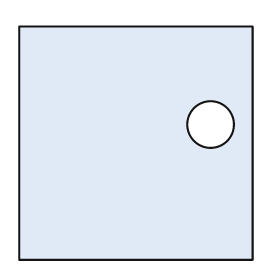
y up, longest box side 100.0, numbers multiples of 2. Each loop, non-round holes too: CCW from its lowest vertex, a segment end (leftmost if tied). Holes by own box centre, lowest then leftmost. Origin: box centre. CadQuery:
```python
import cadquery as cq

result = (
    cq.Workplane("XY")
    .moveTo(-50.0, -50.0)
    .lineTo(50.0, -50.0)
    .lineTo(50.0, 50.0)
    .lineTo(-50.0, 50.0)
    .close()
    .moveTo(32.0, 8.0)
    .circle(10.0)
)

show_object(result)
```